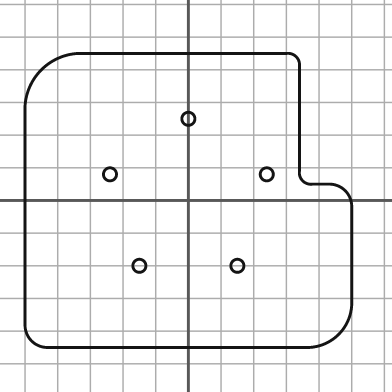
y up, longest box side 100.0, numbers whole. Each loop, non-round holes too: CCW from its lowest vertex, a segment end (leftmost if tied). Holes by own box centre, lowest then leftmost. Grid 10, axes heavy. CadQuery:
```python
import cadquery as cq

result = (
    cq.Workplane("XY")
    .moveTo(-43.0, -45.0)
    .lineTo(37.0, -45.0)
    .threePointArc((46.0, -41.0), (50.0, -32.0))
    .lineTo(50.0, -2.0)
    .threePointArc((48.0, 3.0), (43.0, 5.0))
    .lineTo(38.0, 5.0)
    .threePointArc((35.0, 6.0), (34.0, 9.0))
    .lineTo(34.0, 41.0)
    .threePointArc((33.0, 44.0), (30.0, 45.0))
    .lineTo(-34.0, 45.0)
    .threePointArc((-45.0, 40.0), (-50.0, 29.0))
    .lineTo(-50.0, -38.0)
    .threePointArc((-48.0, -43.0), (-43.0, -45.0))
    .close()
    .moveTo(-15.0, -20.0)
    .circle(2.0)
    .moveTo(15.0, -20.0)
    .circle(2.0)
    .moveTo(-24.0, 8.0)
    .circle(2.0)
    .moveTo(24.0, 8.0)
    .circle(2.0)
    .moveTo(0.0, 25.0)
    .circle(2.0)
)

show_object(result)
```